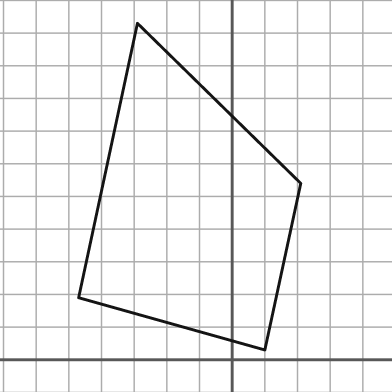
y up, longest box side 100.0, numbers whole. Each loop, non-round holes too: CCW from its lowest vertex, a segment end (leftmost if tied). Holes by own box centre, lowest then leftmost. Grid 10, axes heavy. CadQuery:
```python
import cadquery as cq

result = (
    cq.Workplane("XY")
    .moveTo(10.0, 3.0)
    .lineTo(21.0, 54.0)
    .lineTo(-29.0, 103.0)
    .lineTo(-47.0, 19.0)
    .close()
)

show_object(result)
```